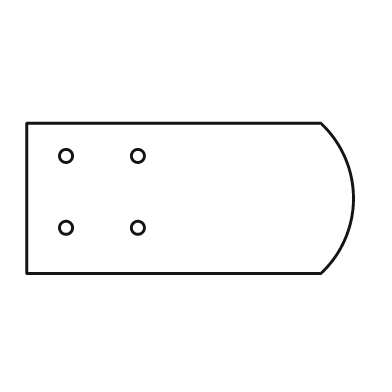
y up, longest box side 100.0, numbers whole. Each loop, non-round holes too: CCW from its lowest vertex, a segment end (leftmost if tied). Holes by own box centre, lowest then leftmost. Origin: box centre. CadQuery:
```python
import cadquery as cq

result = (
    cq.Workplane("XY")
    .moveTo(-50.0, -23.0)
    .lineTo(40.0, -23.0)
    .threePointArc((50.0, 0.0), (40.0, 23.0))
    .lineTo(-50.0, 23.0)
    .close()
    .moveTo(-38.0, -9.0)
    .circle(2.0)
    .moveTo(-16.0, -9.0)
    .circle(2.0)
    .moveTo(-38.0, 13.0)
    .circle(2.0)
    .moveTo(-16.0, 13.0)
    .circle(2.0)
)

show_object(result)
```